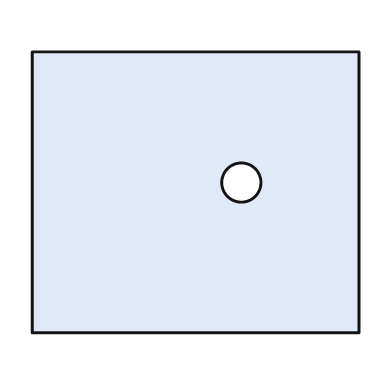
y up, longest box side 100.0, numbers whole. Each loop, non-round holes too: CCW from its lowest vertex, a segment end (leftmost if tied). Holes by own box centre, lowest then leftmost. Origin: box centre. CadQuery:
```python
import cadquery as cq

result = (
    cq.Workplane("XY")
    .moveTo(-50.0, -43.0)
    .lineTo(50.0, -43.0)
    .lineTo(50.0, 43.0)
    .lineTo(-50.0, 43.0)
    .close()
    .moveTo(14.0, 3.0)
    .circle(6.0)
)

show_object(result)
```